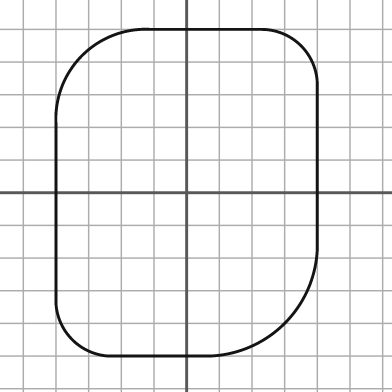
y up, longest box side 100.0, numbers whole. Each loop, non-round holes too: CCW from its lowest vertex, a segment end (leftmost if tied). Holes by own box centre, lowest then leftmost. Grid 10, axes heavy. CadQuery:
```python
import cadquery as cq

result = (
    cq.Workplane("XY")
    .moveTo(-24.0, -50.0)
    .lineTo(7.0, -50.0)
    .threePointArc((30.0, -40.0), (40.0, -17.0))
    .lineTo(40.0, 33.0)
    .threePointArc((35.0, 45.0), (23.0, 50.0))
    .lineTo(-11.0, 50.0)
    .threePointArc((-32.0, 42.0), (-40.0, 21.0))
    .lineTo(-40.0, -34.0)
    .threePointArc((-35.0, -45.0), (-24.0, -50.0))
    .close()
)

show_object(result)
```